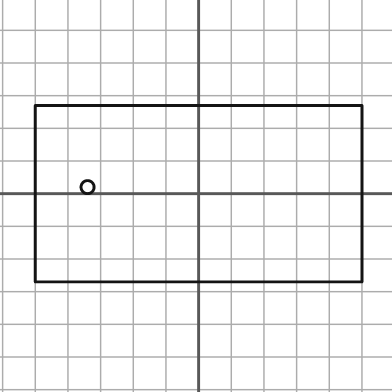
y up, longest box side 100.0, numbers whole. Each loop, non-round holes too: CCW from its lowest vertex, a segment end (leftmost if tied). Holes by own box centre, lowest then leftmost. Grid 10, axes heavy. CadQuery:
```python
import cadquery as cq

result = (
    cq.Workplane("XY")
    .moveTo(-50.0, -27.0)
    .lineTo(50.0, -27.0)
    .lineTo(50.0, 27.0)
    .lineTo(-50.0, 27.0)
    .close()
    .moveTo(-34.0, 2.0)
    .circle(2.0)
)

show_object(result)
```